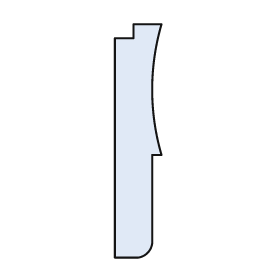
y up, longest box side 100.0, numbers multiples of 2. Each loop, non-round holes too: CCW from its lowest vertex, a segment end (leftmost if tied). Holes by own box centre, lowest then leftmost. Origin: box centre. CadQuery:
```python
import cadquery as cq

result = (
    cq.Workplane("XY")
    .moveTo(-10.0, -50.0)
    .lineTo(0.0, -50.0)
    .threePointArc((4.0, -48.0), (6.0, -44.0))
    .lineTo(6.0, -6.0)
    .lineTo(10.0, -6.0)
    .threePointArc((6.0, 22.0), (10.0, 50.0))
    .lineTo(-2.0, 50.0)
    .lineTo(-2.0, 44.0)
    .lineTo(-10.0, 44.0)
    .close()
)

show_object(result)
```